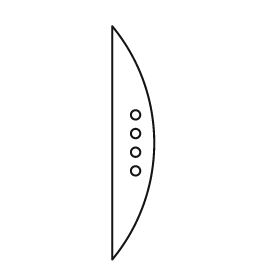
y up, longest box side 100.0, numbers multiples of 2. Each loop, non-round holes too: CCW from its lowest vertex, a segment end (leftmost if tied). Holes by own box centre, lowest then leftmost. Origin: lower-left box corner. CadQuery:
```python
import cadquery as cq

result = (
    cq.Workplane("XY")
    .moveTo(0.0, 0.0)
    .threePointArc((18.0, 50.0), (0.0, 100.0))
    .close()
    .moveTo(10.0, 38.0)
    .circle(2.0)
    .moveTo(10.0, 46.0)
    .circle(2.0)
    .moveTo(10.0, 54.0)
    .circle(2.0)
    .moveTo(10.0, 62.0)
    .circle(2.0)
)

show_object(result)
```